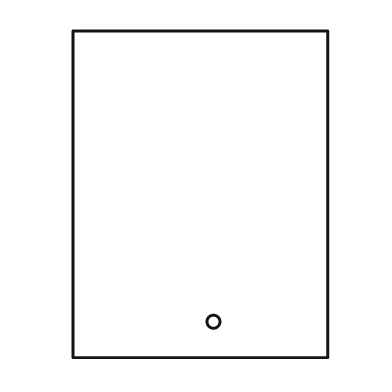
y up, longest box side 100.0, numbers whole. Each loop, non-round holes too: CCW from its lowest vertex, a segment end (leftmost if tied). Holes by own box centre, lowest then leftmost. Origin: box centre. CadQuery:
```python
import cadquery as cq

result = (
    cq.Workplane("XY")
    .moveTo(-39.0, -50.0)
    .lineTo(39.0, -50.0)
    .lineTo(39.0, 50.0)
    .lineTo(-39.0, 50.0)
    .close()
    .moveTo(4.0, -39.0)
    .circle(2.0)
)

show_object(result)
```